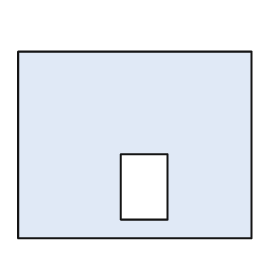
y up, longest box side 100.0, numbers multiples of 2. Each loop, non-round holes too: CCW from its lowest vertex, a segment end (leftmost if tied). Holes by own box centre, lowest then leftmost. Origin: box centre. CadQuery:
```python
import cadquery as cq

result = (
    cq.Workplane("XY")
    .moveTo(-50.0, -40.0)
    .lineTo(50.0, -40.0)
    .lineTo(50.0, 40.0)
    .lineTo(-50.0, 40.0)
    .close()
    .moveTo(-6.0, -32.0)
    .lineTo(14.0, -32.0)
    .lineTo(14.0, -4.0)
    .lineTo(-6.0, -4.0)
    .close()
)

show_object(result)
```